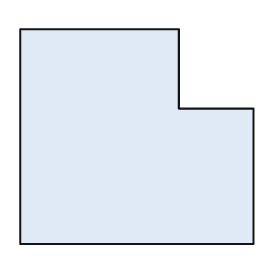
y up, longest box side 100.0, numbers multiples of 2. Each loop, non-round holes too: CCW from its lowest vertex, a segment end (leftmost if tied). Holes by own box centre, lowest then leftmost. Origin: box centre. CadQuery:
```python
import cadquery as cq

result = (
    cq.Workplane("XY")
    .moveTo(-50.0, -46.0)
    .lineTo(50.0, -46.0)
    .lineTo(50.0, 12.0)
    .lineTo(18.0, 12.0)
    .lineTo(18.0, 46.0)
    .lineTo(-50.0, 46.0)
    .close()
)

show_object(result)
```